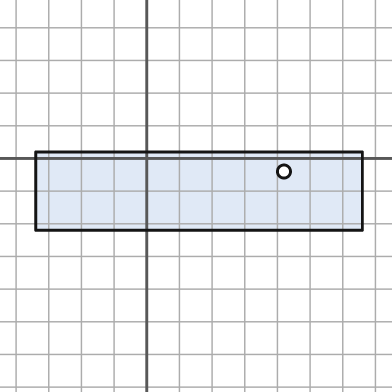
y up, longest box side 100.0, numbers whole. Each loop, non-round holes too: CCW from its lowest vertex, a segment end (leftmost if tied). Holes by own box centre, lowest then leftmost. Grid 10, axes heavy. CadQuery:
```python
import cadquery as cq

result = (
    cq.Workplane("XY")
    .moveTo(-34.0, -22.0)
    .lineTo(66.0, -22.0)
    .lineTo(66.0, 2.0)
    .lineTo(-34.0, 2.0)
    .close()
    .moveTo(42.0, -4.0)
    .circle(2.0)
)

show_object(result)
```